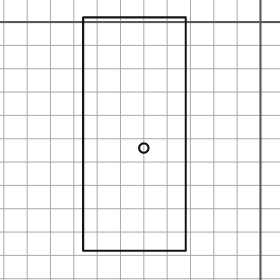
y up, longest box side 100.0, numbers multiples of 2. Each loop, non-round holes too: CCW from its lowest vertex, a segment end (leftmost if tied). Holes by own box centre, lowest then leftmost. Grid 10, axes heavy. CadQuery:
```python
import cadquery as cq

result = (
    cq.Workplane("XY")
    .moveTo(-76.0, -98.0)
    .lineTo(-32.0, -98.0)
    .lineTo(-32.0, 2.0)
    .lineTo(-76.0, 2.0)
    .close()
    .moveTo(-50.0, -54.0)
    .circle(2.0)
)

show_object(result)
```